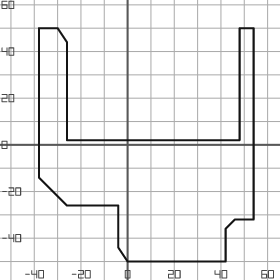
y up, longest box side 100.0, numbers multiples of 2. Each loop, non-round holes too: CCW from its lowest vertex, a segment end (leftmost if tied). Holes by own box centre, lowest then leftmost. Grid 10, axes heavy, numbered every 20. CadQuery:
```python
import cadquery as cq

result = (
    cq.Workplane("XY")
    .moveTo(0.0, -50.0)
    .lineTo(42.0, -50.0)
    .lineTo(42.0, -36.0)
    .lineTo(46.0, -32.0)
    .lineTo(54.0, -32.0)
    .lineTo(54.0, 50.0)
    .lineTo(48.0, 50.0)
    .lineTo(48.0, 2.0)
    .lineTo(-26.0, 2.0)
    .lineTo(-26.0, 44.0)
    .lineTo(-30.0, 50.0)
    .lineTo(-38.0, 50.0)
    .lineTo(-38.0, -14.0)
    .lineTo(-26.0, -26.0)
    .lineTo(-4.0, -26.0)
    .lineTo(-4.0, -44.0)
    .close()
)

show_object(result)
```